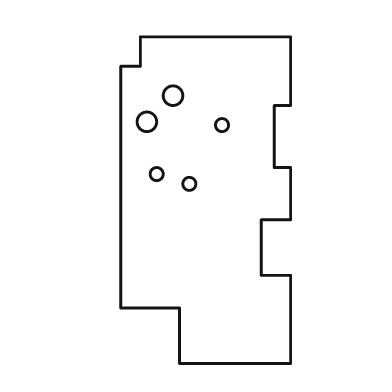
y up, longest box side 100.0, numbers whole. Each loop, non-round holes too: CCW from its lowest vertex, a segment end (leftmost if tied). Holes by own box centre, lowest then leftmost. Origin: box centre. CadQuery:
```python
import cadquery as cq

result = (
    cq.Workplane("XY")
    .moveTo(-8.0, -50.0)
    .lineTo(26.0, -50.0)
    .lineTo(26.0, -23.0)
    .lineTo(17.0, -23.0)
    .lineTo(17.0, -6.0)
    .lineTo(26.0, -6.0)
    .lineTo(26.0, 10.0)
    .lineTo(21.0, 10.0)
    .lineTo(21.0, 29.0)
    .lineTo(26.0, 29.0)
    .lineTo(26.0, 50.0)
    .lineTo(-20.0, 50.0)
    .lineTo(-20.0, 41.0)
    .lineTo(-26.0, 41.0)
    .lineTo(-26.0, -33.0)
    .lineTo(-8.0, -33.0)
    .close()
    .moveTo(-5.0, 5.0)
    .circle(2.0)
    .moveTo(-15.0, 8.0)
    .circle(2.0)
    .moveTo(5.0, 23.0)
    .circle(2.0)
    .moveTo(-18.0, 24.0)
    .circle(3.0)
    .moveTo(-10.0, 32.0)
    .circle(3.0)
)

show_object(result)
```